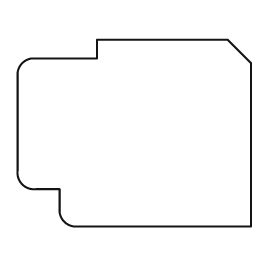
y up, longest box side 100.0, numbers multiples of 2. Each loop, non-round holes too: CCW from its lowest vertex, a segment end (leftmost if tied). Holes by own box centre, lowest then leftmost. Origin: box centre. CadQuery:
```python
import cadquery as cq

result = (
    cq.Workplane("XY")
    .moveTo(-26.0, -40.0)
    .lineTo(50.0, -40.0)
    .lineTo(50.0, 30.0)
    .lineTo(40.0, 40.0)
    .lineTo(-16.0, 40.0)
    .lineTo(-16.0, 32.0)
    .lineTo(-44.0, 32.0)
    .threePointArc((-48.0, 30.0), (-50.0, 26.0))
    .lineTo(-50.0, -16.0)
    .threePointArc((-48.0, -22.0), (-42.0, -24.0))
    .lineTo(-32.0, -24.0)
    .lineTo(-32.0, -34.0)
    .threePointArc((-30.0, -38.0), (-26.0, -40.0))
    .close()
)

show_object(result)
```